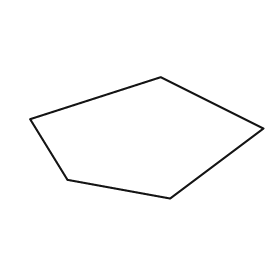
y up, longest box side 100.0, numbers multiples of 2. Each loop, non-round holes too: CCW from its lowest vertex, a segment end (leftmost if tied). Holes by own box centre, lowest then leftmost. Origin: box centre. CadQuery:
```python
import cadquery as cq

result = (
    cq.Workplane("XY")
    .moveTo(10.0, -26.0)
    .lineTo(50.0, 4.0)
    .lineTo(6.0, 26.0)
    .lineTo(-50.0, 8.0)
    .lineTo(-34.0, -18.0)
    .close()
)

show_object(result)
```